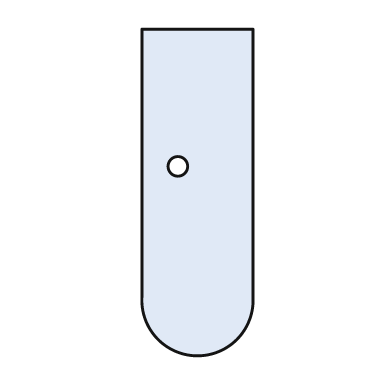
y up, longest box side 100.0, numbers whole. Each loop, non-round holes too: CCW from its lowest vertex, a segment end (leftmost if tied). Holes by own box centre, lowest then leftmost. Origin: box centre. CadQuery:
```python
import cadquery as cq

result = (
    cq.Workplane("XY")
    .moveTo(-17.0, -32.0)
    .threePointArc((0.0, -50.0), (17.0, -32.0))
    .lineTo(17.0, 50.0)
    .lineTo(-17.0, 50.0)
    .close()
    .moveTo(-6.0, 8.0)
    .circle(3.0)
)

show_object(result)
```